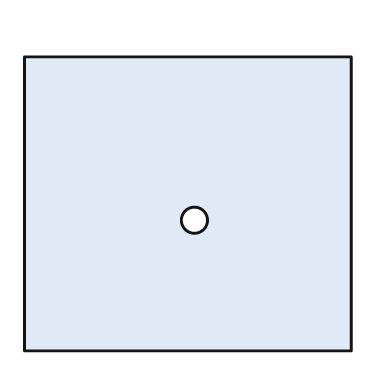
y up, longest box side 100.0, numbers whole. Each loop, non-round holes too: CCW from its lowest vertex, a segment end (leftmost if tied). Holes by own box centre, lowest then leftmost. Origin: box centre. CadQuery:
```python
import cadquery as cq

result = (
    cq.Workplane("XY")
    .moveTo(-50.0, -45.0)
    .lineTo(50.0, -45.0)
    .lineTo(50.0, 45.0)
    .lineTo(-50.0, 45.0)
    .close()
    .moveTo(2.0, -5.0)
    .circle(4.0)
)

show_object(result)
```